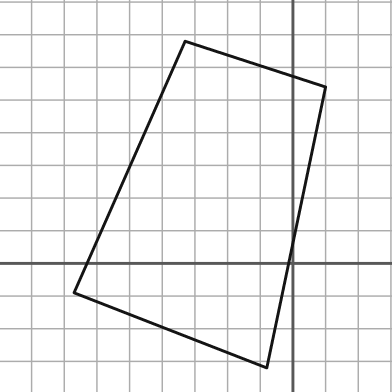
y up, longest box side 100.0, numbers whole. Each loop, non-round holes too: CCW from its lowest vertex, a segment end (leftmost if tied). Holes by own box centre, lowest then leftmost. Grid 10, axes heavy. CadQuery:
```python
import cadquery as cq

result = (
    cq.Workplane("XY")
    .moveTo(-8.0, -32.0)
    .lineTo(10.0, 54.0)
    .lineTo(-33.0, 68.0)
    .lineTo(-67.0, -9.0)
    .close()
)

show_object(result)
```